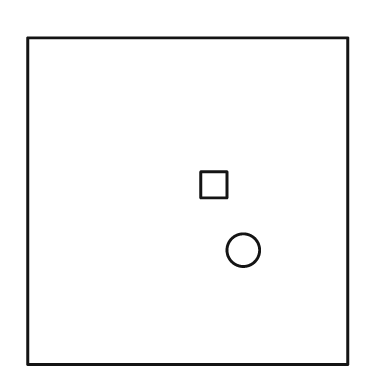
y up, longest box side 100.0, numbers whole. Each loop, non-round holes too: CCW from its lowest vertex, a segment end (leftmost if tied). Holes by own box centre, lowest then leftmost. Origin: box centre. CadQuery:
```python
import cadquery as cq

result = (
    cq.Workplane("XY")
    .moveTo(-49.0, -50.0)
    .lineTo(49.0, -50.0)
    .lineTo(49.0, 50.0)
    .lineTo(-49.0, 50.0)
    .close()
    .moveTo(17.0, -15.0)
    .circle(5.0)
    .moveTo(4.0, 1.0)
    .lineTo(12.0, 1.0)
    .lineTo(12.0, 9.0)
    .lineTo(4.0, 9.0)
    .close()
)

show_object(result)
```